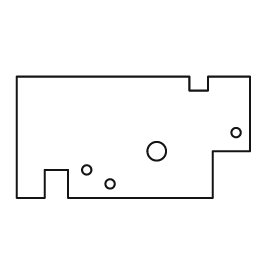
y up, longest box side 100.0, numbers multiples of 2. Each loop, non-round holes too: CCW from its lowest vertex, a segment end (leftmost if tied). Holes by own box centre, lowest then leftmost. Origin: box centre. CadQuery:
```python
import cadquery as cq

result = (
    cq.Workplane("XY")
    .moveTo(-50.0, -26.0)
    .lineTo(-38.0, -26.0)
    .lineTo(-38.0, -14.0)
    .lineTo(-28.0, -14.0)
    .lineTo(-28.0, -26.0)
    .lineTo(34.0, -26.0)
    .lineTo(34.0, -6.0)
    .lineTo(50.0, -6.0)
    .lineTo(50.0, 26.0)
    .lineTo(32.0, 26.0)
    .lineTo(32.0, 20.0)
    .lineTo(24.0, 20.0)
    .lineTo(24.0, 26.0)
    .lineTo(-50.0, 26.0)
    .close()
    .moveTo(-10.0, -20.0)
    .circle(2.0)
    .moveTo(-20.0, -14.0)
    .circle(2.0)
    .moveTo(10.0, -6.0)
    .circle(4.0)
    .moveTo(44.0, 2.0)
    .circle(2.0)
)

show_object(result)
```